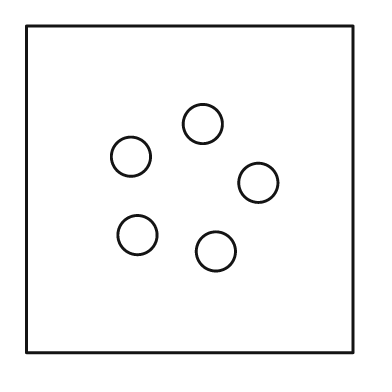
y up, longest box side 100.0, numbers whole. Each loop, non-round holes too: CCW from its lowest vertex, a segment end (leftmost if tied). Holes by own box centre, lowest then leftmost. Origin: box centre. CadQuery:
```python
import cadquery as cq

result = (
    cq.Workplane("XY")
    .moveTo(-50.0, -50.0)
    .lineTo(50.0, -50.0)
    .lineTo(50.0, 50.0)
    .lineTo(-50.0, 50.0)
    .close()
    .moveTo(8.0, -19.0)
    .circle(6.0)
    .moveTo(-16.0, -14.0)
    .circle(6.0)
    .moveTo(21.0, 2.0)
    .circle(6.0)
    .moveTo(-18.0, 10.0)
    .circle(6.0)
    .moveTo(4.0, 20.0)
    .circle(6.0)
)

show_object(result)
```